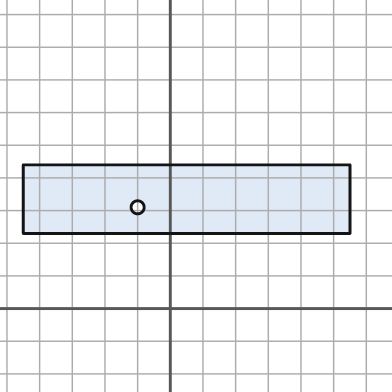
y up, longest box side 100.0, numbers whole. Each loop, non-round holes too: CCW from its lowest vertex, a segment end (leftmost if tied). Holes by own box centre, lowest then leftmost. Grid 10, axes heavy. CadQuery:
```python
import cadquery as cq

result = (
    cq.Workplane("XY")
    .moveTo(-45.0, 23.0)
    .lineTo(55.0, 23.0)
    .lineTo(55.0, 44.0)
    .lineTo(-45.0, 44.0)
    .close()
    .moveTo(-10.0, 31.0)
    .circle(2.0)
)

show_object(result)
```